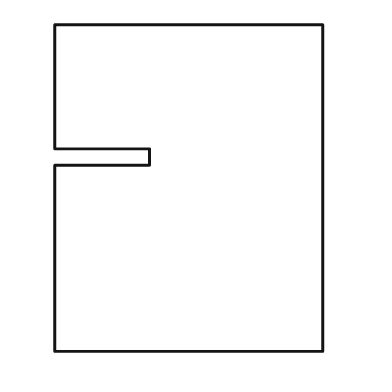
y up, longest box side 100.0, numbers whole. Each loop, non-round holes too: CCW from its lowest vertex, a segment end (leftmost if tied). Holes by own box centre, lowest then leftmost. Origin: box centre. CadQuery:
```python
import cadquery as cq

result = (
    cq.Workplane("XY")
    .moveTo(-41.0, -50.0)
    .lineTo(41.0, -50.0)
    .lineTo(41.0, 50.0)
    .lineTo(-41.0, 50.0)
    .lineTo(-41.0, 12.0)
    .lineTo(-12.0, 12.0)
    .lineTo(-12.0, 7.0)
    .lineTo(-41.0, 7.0)
    .close()
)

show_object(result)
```